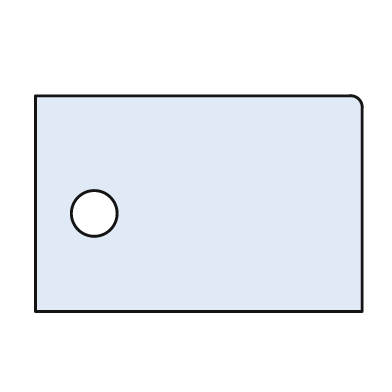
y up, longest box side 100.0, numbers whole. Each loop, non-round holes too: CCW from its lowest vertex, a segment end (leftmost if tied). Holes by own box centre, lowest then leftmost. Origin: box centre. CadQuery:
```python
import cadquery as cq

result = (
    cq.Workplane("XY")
    .moveTo(-50.0, -33.0)
    .lineTo(50.0, -33.0)
    .lineTo(50.0, 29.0)
    .threePointArc((49.0, 32.0), (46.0, 33.0))
    .lineTo(-50.0, 33.0)
    .close()
    .moveTo(-32.0, -3.0)
    .circle(7.0)
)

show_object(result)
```